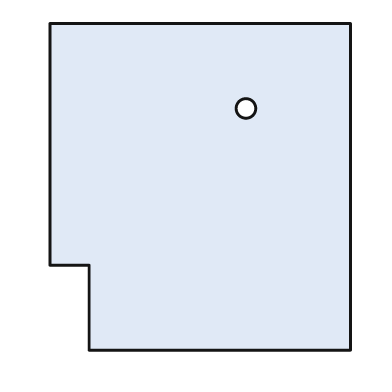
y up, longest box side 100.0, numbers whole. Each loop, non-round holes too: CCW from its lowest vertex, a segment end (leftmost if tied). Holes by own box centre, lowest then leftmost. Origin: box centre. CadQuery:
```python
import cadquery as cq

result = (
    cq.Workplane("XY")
    .moveTo(-34.0, -50.0)
    .lineTo(46.0, -50.0)
    .lineTo(46.0, 50.0)
    .lineTo(-46.0, 50.0)
    .lineTo(-46.0, -24.0)
    .lineTo(-34.0, -24.0)
    .close()
    .moveTo(14.0, 24.0)
    .circle(3.0)
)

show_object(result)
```